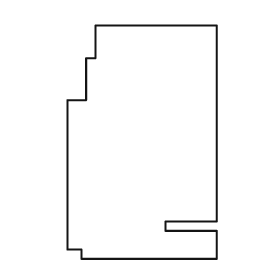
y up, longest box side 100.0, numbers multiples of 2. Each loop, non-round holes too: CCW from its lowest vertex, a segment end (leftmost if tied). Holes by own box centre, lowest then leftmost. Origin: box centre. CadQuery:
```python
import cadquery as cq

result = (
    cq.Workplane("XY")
    .moveTo(-26.0, -50.0)
    .lineTo(32.0, -50.0)
    .lineTo(32.0, -38.0)
    .lineTo(10.0, -38.0)
    .lineTo(10.0, -34.0)
    .lineTo(32.0, -34.0)
    .lineTo(32.0, 50.0)
    .lineTo(-20.0, 50.0)
    .lineTo(-20.0, 36.0)
    .lineTo(-24.0, 36.0)
    .lineTo(-24.0, 18.0)
    .lineTo(-32.0, 18.0)
    .lineTo(-32.0, -46.0)
    .lineTo(-26.0, -46.0)
    .close()
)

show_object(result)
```